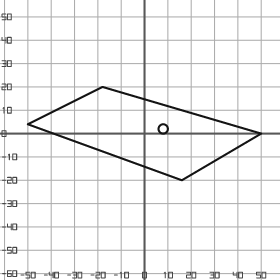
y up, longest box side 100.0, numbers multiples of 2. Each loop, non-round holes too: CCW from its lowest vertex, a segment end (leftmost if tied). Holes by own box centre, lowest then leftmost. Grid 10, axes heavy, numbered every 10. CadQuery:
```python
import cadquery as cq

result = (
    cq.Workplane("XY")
    .moveTo(16.0, -20.0)
    .lineTo(50.0, 0.0)
    .lineTo(-18.0, 20.0)
    .lineTo(-50.0, 4.0)
    .close()
    .moveTo(8.0, 2.0)
    .circle(2.0)
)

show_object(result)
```